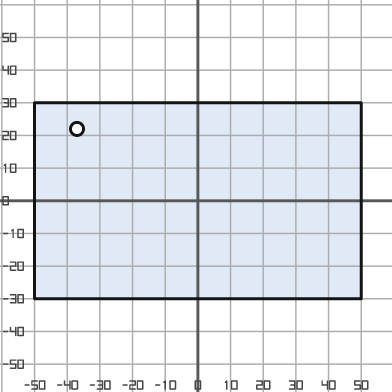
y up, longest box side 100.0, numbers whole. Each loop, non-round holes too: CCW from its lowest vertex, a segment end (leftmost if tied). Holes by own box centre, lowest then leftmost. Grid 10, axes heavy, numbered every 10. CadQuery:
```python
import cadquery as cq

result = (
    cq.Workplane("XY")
    .moveTo(-50.0, -30.0)
    .lineTo(50.0, -30.0)
    .lineTo(50.0, 30.0)
    .lineTo(-50.0, 30.0)
    .close()
    .moveTo(-37.0, 22.0)
    .circle(2.0)
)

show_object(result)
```